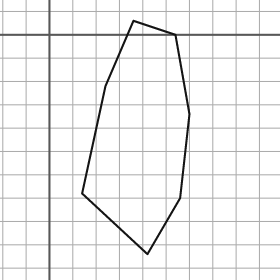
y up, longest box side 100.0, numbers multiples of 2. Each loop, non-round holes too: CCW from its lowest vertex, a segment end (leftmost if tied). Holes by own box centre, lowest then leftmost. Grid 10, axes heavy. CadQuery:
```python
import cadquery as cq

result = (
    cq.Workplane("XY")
    .moveTo(42.0, -94.0)
    .lineTo(56.0, -70.0)
    .lineTo(60.0, -34.0)
    .lineTo(54.0, 0.0)
    .lineTo(36.0, 6.0)
    .lineTo(24.0, -22.0)
    .lineTo(14.0, -68.0)
    .close()
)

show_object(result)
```